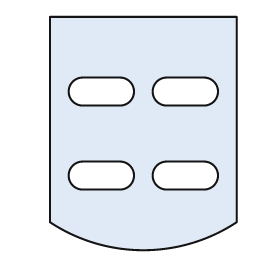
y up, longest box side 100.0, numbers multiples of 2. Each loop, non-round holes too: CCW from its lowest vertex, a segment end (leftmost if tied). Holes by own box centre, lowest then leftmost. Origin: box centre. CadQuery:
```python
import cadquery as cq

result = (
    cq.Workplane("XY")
    .moveTo(-40.0, -38.0)
    .threePointArc((0.0, -50.0), (40.0, -38.0))
    .lineTo(40.0, 50.0)
    .lineTo(-40.0, 50.0)
    .close()
    .moveTo(-26.0, -24.0)
    .lineTo(-10.0, -24.0)
    .threePointArc((-4.0, -18.0), (-10.0, -12.0))
    .lineTo(-26.0, -12.0)
    .threePointArc((-32.0, -18.0), (-26.0, -24.0))
    .close()
    .moveTo(10.0, -24.0)
    .lineTo(26.0, -24.0)
    .threePointArc((32.0, -18.0), (26.0, -12.0))
    .lineTo(10.0, -12.0)
    .threePointArc((4.0, -18.0), (10.0, -24.0))
    .close()
    .moveTo(-26.0, 12.0)
    .lineTo(-10.0, 12.0)
    .threePointArc((-4.0, 18.0), (-10.0, 24.0))
    .lineTo(-26.0, 24.0)
    .threePointArc((-32.0, 18.0), (-26.0, 12.0))
    .close()
    .moveTo(10.0, 12.0)
    .lineTo(26.0, 12.0)
    .threePointArc((32.0, 18.0), (26.0, 24.0))
    .lineTo(10.0, 24.0)
    .threePointArc((4.0, 18.0), (10.0, 12.0))
    .close()
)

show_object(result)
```